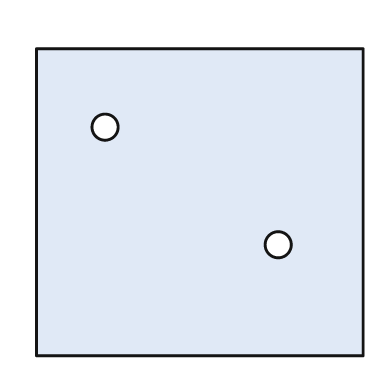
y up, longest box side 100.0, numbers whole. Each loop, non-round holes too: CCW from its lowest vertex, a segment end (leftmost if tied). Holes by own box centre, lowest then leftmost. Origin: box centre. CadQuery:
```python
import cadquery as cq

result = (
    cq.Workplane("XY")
    .moveTo(-50.0, -47.0)
    .lineTo(50.0, -47.0)
    .lineTo(50.0, 47.0)
    .lineTo(-50.0, 47.0)
    .close()
    .moveTo(24.0, -13.0)
    .circle(4.0)
    .moveTo(-29.0, 23.0)
    .circle(4.0)
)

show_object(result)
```